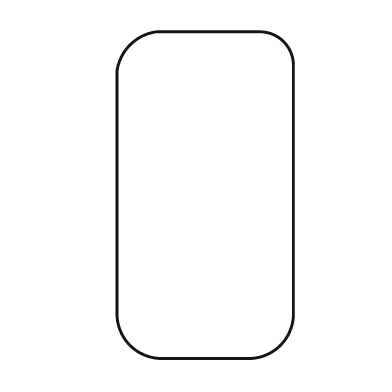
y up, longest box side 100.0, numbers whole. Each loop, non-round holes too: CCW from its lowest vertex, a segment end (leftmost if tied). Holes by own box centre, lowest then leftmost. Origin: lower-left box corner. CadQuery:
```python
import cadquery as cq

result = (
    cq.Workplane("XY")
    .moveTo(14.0, 0.0)
    .lineTo(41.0, 0.0)
    .threePointArc((50.0, 4.0), (54.0, 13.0))
    .lineTo(54.0, 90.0)
    .threePointArc((51.0, 97.0), (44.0, 100.0))
    .lineTo(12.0, 100.0)
    .threePointArc((4.0, 96.0), (0.0, 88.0))
    .lineTo(0.0, 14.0)
    .threePointArc((4.0, 4.0), (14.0, 0.0))
    .close()
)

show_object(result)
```